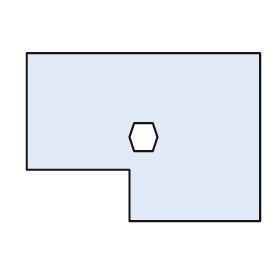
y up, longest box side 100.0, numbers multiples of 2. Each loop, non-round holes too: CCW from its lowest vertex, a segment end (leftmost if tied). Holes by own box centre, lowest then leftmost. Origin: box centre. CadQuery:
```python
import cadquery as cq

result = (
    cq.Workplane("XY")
    .moveTo(-6.0, -36.0)
    .lineTo(50.0, -36.0)
    .lineTo(50.0, 36.0)
    .lineTo(-50.0, 36.0)
    .lineTo(-50.0, -14.0)
    .lineTo(-6.0, -14.0)
    .close()
    .moveTo(-4.0, -6.0)
    .lineTo(4.0, -6.0)
    .lineTo(6.0, 0.0)
    .lineTo(4.0, 6.0)
    .lineTo(-4.0, 6.0)
    .lineTo(-6.0, 0.0)
    .close()
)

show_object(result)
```